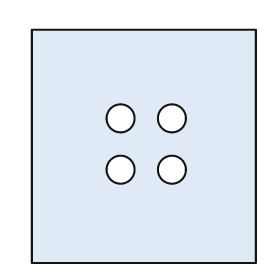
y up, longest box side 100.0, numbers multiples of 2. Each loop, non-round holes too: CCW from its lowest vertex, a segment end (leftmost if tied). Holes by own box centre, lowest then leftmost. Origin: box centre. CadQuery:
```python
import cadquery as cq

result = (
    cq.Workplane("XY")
    .moveTo(-48.0, -50.0)
    .lineTo(48.0, -50.0)
    .lineTo(48.0, 50.0)
    .lineTo(-48.0, 50.0)
    .close()
    .moveTo(-10.0, -10.0)
    .circle(6.0)
    .moveTo(12.0, -10.0)
    .circle(6.0)
    .moveTo(-10.0, 12.0)
    .circle(6.0)
    .moveTo(12.0, 12.0)
    .circle(6.0)
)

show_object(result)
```